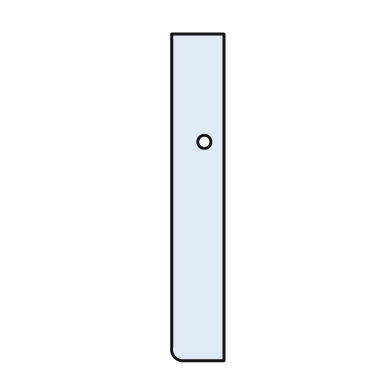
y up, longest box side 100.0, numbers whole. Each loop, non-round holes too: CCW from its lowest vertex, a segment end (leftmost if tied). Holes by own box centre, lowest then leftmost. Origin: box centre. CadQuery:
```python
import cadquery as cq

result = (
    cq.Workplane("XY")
    .moveTo(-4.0, -50.0)
    .lineTo(8.0, -50.0)
    .lineTo(8.0, 50.0)
    .lineTo(-8.0, 50.0)
    .lineTo(-8.0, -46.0)
    .threePointArc((-7.0, -49.0), (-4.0, -50.0))
    .close()
    .moveTo(2.0, 17.0)
    .circle(2.0)
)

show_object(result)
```